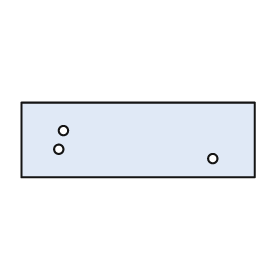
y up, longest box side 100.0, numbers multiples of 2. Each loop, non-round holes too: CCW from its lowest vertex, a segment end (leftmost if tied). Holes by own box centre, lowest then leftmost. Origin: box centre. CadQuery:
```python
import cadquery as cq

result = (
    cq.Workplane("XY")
    .moveTo(-50.0, -16.0)
    .lineTo(50.0, -16.0)
    .lineTo(50.0, 16.0)
    .lineTo(-50.0, 16.0)
    .close()
    .moveTo(32.0, -8.0)
    .circle(2.0)
    .moveTo(-34.0, -4.0)
    .circle(2.0)
    .moveTo(-32.0, 4.0)
    .circle(2.0)
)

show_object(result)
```